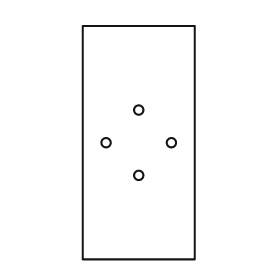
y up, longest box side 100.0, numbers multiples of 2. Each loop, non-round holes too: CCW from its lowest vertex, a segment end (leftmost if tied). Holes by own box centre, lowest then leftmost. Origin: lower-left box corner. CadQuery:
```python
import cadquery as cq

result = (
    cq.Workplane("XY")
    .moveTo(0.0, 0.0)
    .lineTo(48.0, 0.0)
    .lineTo(48.0, 100.0)
    .lineTo(0.0, 100.0)
    .close()
    .moveTo(24.0, 36.0)
    .circle(2.0)
    .moveTo(10.0, 50.0)
    .circle(2.0)
    .moveTo(38.0, 50.0)
    .circle(2.0)
    .moveTo(24.0, 64.0)
    .circle(2.0)
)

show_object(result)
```